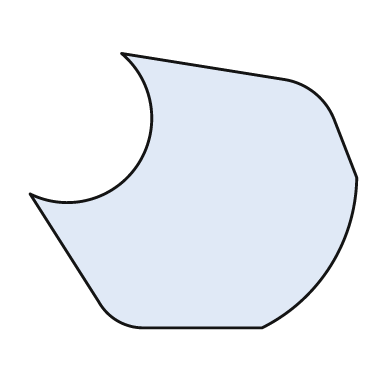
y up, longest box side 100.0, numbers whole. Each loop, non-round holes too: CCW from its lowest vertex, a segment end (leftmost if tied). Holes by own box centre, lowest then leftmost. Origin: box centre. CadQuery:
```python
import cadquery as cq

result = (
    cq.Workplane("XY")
    .moveTo(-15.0, -42.0)
    .lineTo(21.0, -42.0)
    .threePointArc((42.0, -23.0), (50.0, 4.0))
    .lineTo(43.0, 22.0)
    .threePointArc((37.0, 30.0), (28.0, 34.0))
    .lineTo(-22.0, 42.0)
    .threePointArc((-17.0, 8.0), (-50.0, -1.0))
    .lineTo(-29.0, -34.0)
    .threePointArc((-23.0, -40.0), (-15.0, -42.0))
    .close()
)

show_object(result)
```